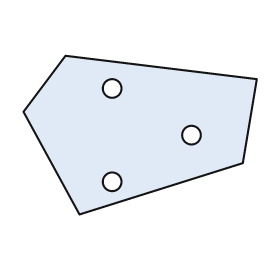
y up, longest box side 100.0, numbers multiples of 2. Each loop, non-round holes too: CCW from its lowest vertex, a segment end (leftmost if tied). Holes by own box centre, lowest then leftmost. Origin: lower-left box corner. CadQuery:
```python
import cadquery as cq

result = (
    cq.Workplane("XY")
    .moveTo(24.0, 0.0)
    .lineTo(94.0, 22.0)
    .lineTo(100.0, 58.0)
    .lineTo(18.0, 68.0)
    .lineTo(0.0, 44.0)
    .close()
    .moveTo(38.0, 14.0)
    .circle(4.0)
    .moveTo(72.0, 34.0)
    .circle(4.0)
    .moveTo(38.0, 54.0)
    .circle(4.0)
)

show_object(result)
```